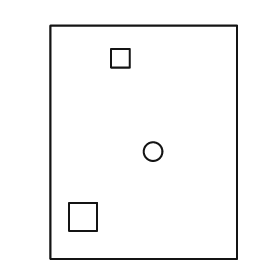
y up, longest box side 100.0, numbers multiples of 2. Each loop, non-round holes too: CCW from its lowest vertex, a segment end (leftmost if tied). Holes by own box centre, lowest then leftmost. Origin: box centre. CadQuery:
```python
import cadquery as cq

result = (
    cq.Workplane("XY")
    .moveTo(-40.0, -50.0)
    .lineTo(40.0, -50.0)
    .lineTo(40.0, 50.0)
    .lineTo(-40.0, 50.0)
    .close()
    .moveTo(-32.0, -38.0)
    .lineTo(-20.0, -38.0)
    .lineTo(-20.0, -26.0)
    .lineTo(-32.0, -26.0)
    .close()
    .moveTo(4.0, -4.0)
    .circle(4.0)
    .moveTo(-14.0, 32.0)
    .lineTo(-6.0, 32.0)
    .lineTo(-6.0, 40.0)
    .lineTo(-14.0, 40.0)
    .close()
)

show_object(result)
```